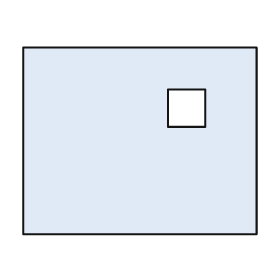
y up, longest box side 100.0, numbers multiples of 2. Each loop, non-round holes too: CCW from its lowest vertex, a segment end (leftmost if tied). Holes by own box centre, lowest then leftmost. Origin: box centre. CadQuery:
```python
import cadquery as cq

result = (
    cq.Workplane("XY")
    .moveTo(-50.0, -40.0)
    .lineTo(50.0, -40.0)
    .lineTo(50.0, 40.0)
    .lineTo(-50.0, 40.0)
    .close()
    .moveTo(12.0, 6.0)
    .lineTo(28.0, 6.0)
    .lineTo(28.0, 22.0)
    .lineTo(12.0, 22.0)
    .close()
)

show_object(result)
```